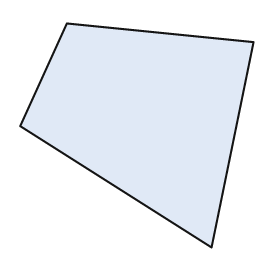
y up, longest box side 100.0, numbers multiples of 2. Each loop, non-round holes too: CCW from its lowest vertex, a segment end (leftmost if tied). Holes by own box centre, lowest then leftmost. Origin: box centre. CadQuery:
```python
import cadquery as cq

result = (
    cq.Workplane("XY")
    .moveTo(32.0, -48.0)
    .lineTo(50.0, 40.0)
    .lineTo(-30.0, 48.0)
    .lineTo(-50.0, 4.0)
    .close()
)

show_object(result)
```